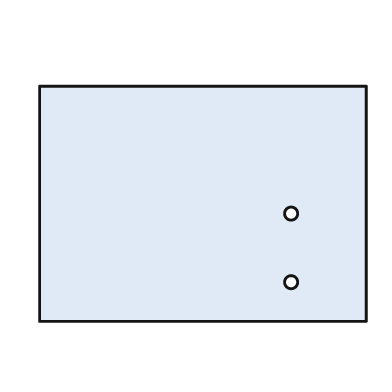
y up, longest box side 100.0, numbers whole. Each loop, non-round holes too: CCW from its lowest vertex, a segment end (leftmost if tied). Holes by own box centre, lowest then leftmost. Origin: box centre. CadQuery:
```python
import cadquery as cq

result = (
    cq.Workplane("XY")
    .moveTo(-50.0, -36.0)
    .lineTo(50.0, -36.0)
    .lineTo(50.0, 36.0)
    .lineTo(-50.0, 36.0)
    .close()
    .moveTo(27.0, -24.0)
    .circle(2.0)
    .moveTo(27.0, -3.0)
    .circle(2.0)
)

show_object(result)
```